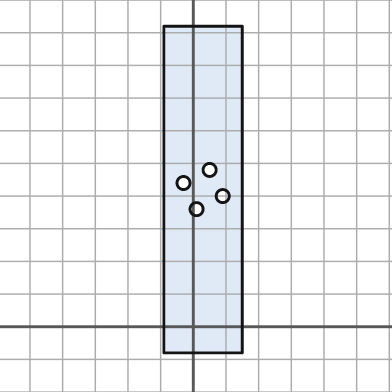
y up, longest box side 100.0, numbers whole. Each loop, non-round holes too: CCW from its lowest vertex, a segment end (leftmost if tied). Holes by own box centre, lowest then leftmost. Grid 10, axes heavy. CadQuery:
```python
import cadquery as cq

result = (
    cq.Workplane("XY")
    .moveTo(-9.0, -8.0)
    .lineTo(15.0, -8.0)
    .lineTo(15.0, 92.0)
    .lineTo(-9.0, 92.0)
    .close()
    .moveTo(1.0, 36.0)
    .circle(2.0)
    .moveTo(9.0, 40.0)
    .circle(2.0)
    .moveTo(-3.0, 44.0)
    .circle(2.0)
    .moveTo(5.0, 48.0)
    .circle(2.0)
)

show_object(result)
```